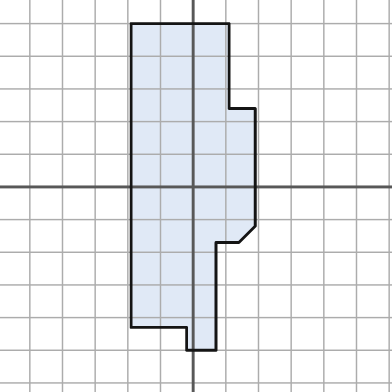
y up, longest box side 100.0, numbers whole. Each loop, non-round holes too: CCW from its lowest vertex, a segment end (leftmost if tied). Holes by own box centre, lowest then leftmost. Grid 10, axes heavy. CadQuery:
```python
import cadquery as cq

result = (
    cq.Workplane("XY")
    .moveTo(-2.0, -50.0)
    .lineTo(7.0, -50.0)
    .lineTo(7.0, -17.0)
    .lineTo(14.0, -17.0)
    .lineTo(19.0, -12.0)
    .lineTo(19.0, 24.0)
    .lineTo(11.0, 24.0)
    .lineTo(11.0, 50.0)
    .lineTo(-19.0, 50.0)
    .lineTo(-19.0, -43.0)
    .lineTo(-2.0, -43.0)
    .close()
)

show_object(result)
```